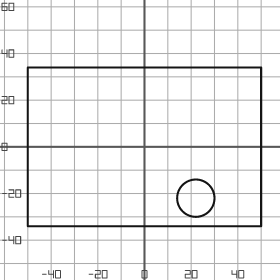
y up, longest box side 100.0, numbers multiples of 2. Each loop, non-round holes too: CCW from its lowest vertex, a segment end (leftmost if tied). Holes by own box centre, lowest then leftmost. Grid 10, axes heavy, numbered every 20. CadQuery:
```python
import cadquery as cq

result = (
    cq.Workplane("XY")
    .moveTo(-50.0, -34.0)
    .lineTo(50.0, -34.0)
    .lineTo(50.0, 34.0)
    .lineTo(-50.0, 34.0)
    .close()
    .moveTo(22.0, -22.0)
    .circle(8.0)
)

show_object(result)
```